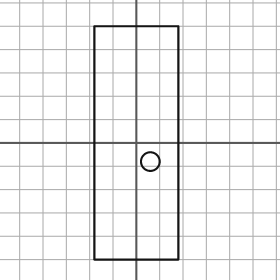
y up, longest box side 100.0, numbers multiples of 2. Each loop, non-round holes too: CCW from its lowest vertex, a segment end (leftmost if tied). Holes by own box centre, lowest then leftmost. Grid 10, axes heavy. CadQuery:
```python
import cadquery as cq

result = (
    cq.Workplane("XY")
    .moveTo(-18.0, -50.0)
    .lineTo(18.0, -50.0)
    .lineTo(18.0, 50.0)
    .lineTo(-18.0, 50.0)
    .close()
    .moveTo(6.0, -8.0)
    .circle(4.0)
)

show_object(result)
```